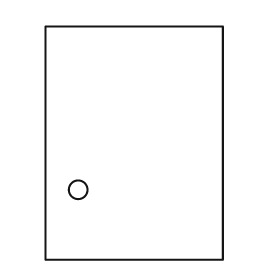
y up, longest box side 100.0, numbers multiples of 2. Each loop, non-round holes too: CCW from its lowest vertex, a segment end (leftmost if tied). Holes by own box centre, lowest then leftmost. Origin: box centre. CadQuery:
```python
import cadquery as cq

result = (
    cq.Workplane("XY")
    .moveTo(-38.0, -50.0)
    .lineTo(38.0, -50.0)
    .lineTo(38.0, 50.0)
    .lineTo(-38.0, 50.0)
    .close()
    .moveTo(-24.0, -20.0)
    .circle(4.0)
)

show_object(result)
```